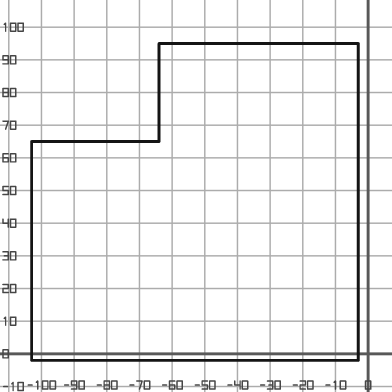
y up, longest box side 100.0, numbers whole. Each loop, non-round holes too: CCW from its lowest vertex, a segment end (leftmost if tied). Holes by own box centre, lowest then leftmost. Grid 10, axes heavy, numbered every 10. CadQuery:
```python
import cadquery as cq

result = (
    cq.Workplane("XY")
    .moveTo(-103.0, -2.0)
    .lineTo(-3.0, -2.0)
    .lineTo(-3.0, 95.0)
    .lineTo(-64.0, 95.0)
    .lineTo(-64.0, 65.0)
    .lineTo(-103.0, 65.0)
    .close()
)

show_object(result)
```